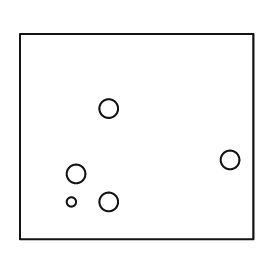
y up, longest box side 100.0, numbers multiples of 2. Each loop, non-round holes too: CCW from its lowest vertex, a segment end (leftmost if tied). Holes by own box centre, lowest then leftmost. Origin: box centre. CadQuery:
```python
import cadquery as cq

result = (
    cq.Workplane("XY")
    .moveTo(-50.0, -44.0)
    .lineTo(50.0, -44.0)
    .lineTo(50.0, 44.0)
    .lineTo(-50.0, 44.0)
    .close()
    .moveTo(-28.0, -28.0)
    .circle(2.0)
    .moveTo(-12.0, -28.0)
    .circle(4.0)
    .moveTo(-26.0, -16.0)
    .circle(4.0)
    .moveTo(40.0, -10.0)
    .circle(4.0)
    .moveTo(-12.0, 12.0)
    .circle(4.0)
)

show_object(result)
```